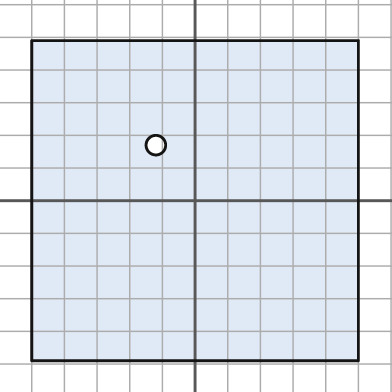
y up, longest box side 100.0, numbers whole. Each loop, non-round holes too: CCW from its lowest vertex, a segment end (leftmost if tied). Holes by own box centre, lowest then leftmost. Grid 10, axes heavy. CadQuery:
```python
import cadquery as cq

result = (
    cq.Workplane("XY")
    .moveTo(-50.0, -49.0)
    .lineTo(50.0, -49.0)
    .lineTo(50.0, 49.0)
    .lineTo(-50.0, 49.0)
    .close()
    .moveTo(-12.0, 17.0)
    .circle(3.0)
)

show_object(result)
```